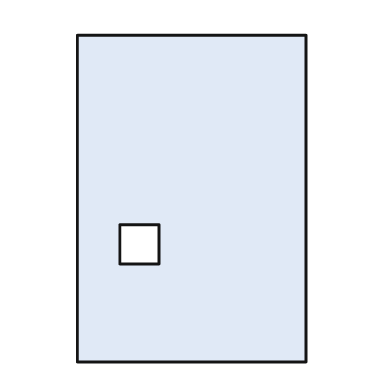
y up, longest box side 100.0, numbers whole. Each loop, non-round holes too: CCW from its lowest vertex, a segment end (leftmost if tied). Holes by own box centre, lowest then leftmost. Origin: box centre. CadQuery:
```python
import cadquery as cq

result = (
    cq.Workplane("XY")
    .moveTo(-35.0, -50.0)
    .lineTo(35.0, -50.0)
    .lineTo(35.0, 50.0)
    .lineTo(-35.0, 50.0)
    .close()
    .moveTo(-22.0, -20.0)
    .lineTo(-10.0, -20.0)
    .lineTo(-10.0, -8.0)
    .lineTo(-22.0, -8.0)
    .close()
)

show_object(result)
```